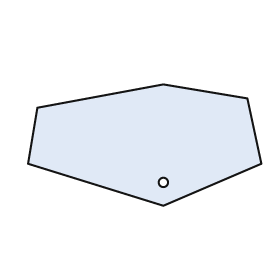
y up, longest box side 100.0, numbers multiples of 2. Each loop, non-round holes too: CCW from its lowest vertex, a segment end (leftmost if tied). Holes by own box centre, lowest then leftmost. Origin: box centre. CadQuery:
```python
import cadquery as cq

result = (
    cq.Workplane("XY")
    .moveTo(8.0, -26.0)
    .lineTo(50.0, -8.0)
    .lineTo(44.0, 20.0)
    .lineTo(8.0, 26.0)
    .lineTo(-46.0, 16.0)
    .lineTo(-50.0, -8.0)
    .close()
    .moveTo(8.0, -16.0)
    .circle(2.0)
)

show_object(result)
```